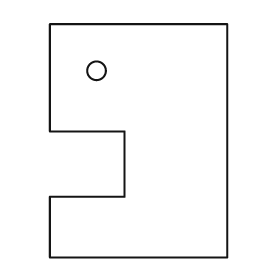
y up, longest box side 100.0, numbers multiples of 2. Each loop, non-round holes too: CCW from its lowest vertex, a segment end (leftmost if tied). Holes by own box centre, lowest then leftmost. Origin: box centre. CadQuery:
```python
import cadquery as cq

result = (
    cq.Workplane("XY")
    .moveTo(-38.0, -50.0)
    .lineTo(38.0, -50.0)
    .lineTo(38.0, 50.0)
    .lineTo(-38.0, 50.0)
    .lineTo(-38.0, 4.0)
    .lineTo(-6.0, 4.0)
    .lineTo(-6.0, -24.0)
    .lineTo(-38.0, -24.0)
    .close()
    .moveTo(-18.0, 30.0)
    .circle(4.0)
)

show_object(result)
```